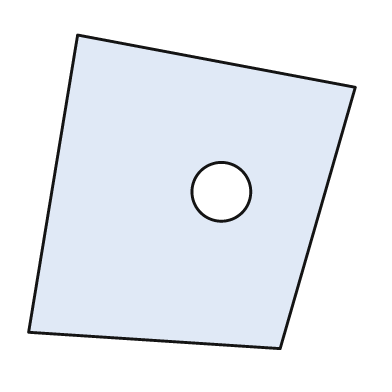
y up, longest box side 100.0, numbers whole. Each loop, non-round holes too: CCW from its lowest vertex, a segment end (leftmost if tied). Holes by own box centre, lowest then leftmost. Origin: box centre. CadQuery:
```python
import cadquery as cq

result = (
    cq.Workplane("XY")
    .moveTo(27.0, -48.0)
    .lineTo(50.0, 32.0)
    .lineTo(-35.0, 48.0)
    .lineTo(-50.0, -43.0)
    .close()
    .moveTo(9.0, 0.0)
    .circle(9.0)
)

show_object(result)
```